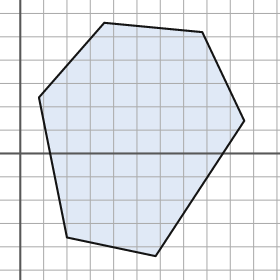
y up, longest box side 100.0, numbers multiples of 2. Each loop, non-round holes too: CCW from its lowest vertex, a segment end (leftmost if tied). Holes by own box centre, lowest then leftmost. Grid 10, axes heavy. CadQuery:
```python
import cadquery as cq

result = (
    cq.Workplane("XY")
    .moveTo(58.0, -44.0)
    .lineTo(96.0, 14.0)
    .lineTo(78.0, 52.0)
    .lineTo(36.0, 56.0)
    .lineTo(8.0, 24.0)
    .lineTo(20.0, -36.0)
    .close()
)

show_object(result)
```